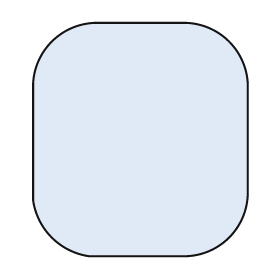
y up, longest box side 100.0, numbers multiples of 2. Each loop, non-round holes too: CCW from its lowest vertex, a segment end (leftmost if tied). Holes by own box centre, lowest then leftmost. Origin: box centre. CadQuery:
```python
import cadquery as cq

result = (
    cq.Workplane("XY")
    .moveTo(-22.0, -50.0)
    .lineTo(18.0, -50.0)
    .threePointArc((38.0, -42.0), (46.0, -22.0))
    .lineTo(46.0, 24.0)
    .threePointArc((38.0, 42.0), (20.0, 50.0))
    .lineTo(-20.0, 50.0)
    .threePointArc((-38.0, 42.0), (-46.0, 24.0))
    .lineTo(-46.0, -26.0)
    .threePointArc((-38.0, -42.0), (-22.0, -50.0))
    .close()
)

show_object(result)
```